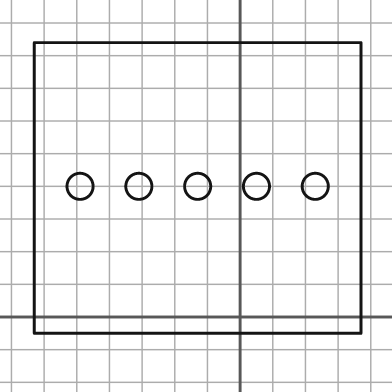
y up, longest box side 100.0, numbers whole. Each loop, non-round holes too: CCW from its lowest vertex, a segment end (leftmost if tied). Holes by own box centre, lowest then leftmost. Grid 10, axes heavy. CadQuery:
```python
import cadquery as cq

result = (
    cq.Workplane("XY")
    .moveTo(-63.0, -5.0)
    .lineTo(37.0, -5.0)
    .lineTo(37.0, 84.0)
    .lineTo(-63.0, 84.0)
    .close()
    .moveTo(-49.0, 40.0)
    .circle(4.0)
    .moveTo(-31.0, 40.0)
    .circle(4.0)
    .moveTo(-13.0, 40.0)
    .circle(4.0)
    .moveTo(5.0, 40.0)
    .circle(4.0)
    .moveTo(23.0, 40.0)
    .circle(4.0)
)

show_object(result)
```